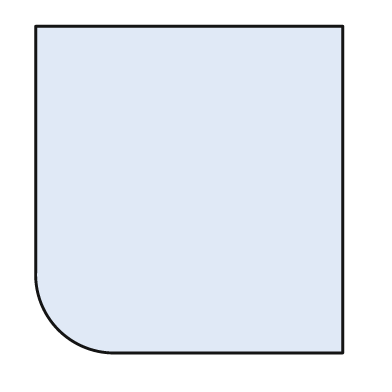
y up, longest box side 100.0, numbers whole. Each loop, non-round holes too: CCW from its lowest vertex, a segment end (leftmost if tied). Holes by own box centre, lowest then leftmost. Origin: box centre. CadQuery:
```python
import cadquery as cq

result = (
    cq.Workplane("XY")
    .moveTo(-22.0, -50.0)
    .lineTo(47.0, -50.0)
    .lineTo(47.0, 50.0)
    .lineTo(-47.0, 50.0)
    .lineTo(-47.0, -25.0)
    .threePointArc((-40.0, -43.0), (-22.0, -50.0))
    .close()
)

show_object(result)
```